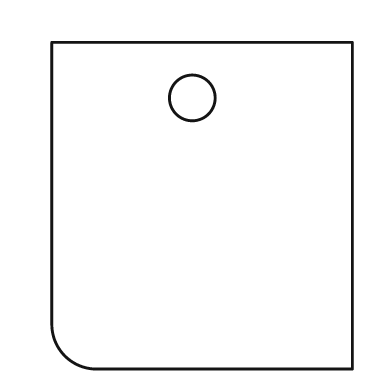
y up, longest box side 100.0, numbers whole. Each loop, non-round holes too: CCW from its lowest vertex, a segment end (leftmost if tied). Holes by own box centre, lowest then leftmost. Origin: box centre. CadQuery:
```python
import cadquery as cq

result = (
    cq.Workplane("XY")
    .moveTo(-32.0, -50.0)
    .lineTo(46.0, -50.0)
    .lineTo(46.0, 50.0)
    .lineTo(-46.0, 50.0)
    .lineTo(-46.0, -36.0)
    .threePointArc((-42.0, -46.0), (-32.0, -50.0))
    .close()
    .moveTo(-3.0, 33.0)
    .circle(7.0)
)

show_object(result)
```